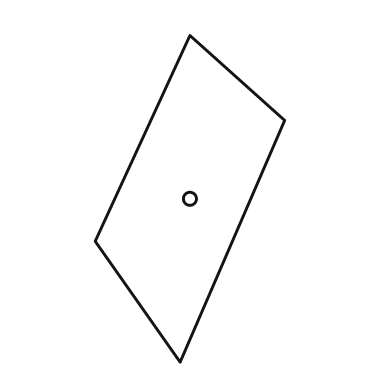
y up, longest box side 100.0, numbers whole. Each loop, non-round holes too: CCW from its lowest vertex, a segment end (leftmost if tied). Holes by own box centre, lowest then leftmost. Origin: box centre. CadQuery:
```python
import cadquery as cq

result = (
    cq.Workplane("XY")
    .moveTo(-3.0, -50.0)
    .lineTo(29.0, 24.0)
    .lineTo(0.0, 50.0)
    .lineTo(-29.0, -13.0)
    .close()
    .moveTo(0.0, 0.0)
    .circle(2.0)
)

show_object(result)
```